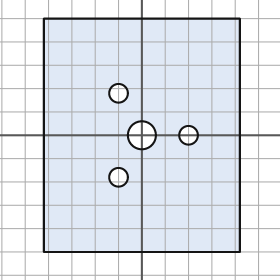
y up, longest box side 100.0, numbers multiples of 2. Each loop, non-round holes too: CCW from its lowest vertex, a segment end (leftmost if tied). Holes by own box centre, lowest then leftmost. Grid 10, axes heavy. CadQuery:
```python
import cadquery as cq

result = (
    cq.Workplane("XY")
    .moveTo(-42.0, -50.0)
    .lineTo(42.0, -50.0)
    .lineTo(42.0, 50.0)
    .lineTo(-42.0, 50.0)
    .close()
    .moveTo(-10.0, -18.0)
    .circle(4.0)
    .moveTo(0.0, 0.0)
    .circle(6.0)
    .moveTo(20.0, 0.0)
    .circle(4.0)
    .moveTo(-10.0, 18.0)
    .circle(4.0)
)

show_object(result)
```